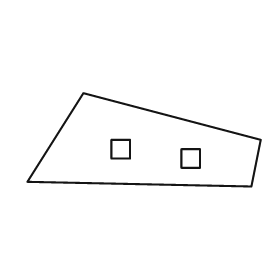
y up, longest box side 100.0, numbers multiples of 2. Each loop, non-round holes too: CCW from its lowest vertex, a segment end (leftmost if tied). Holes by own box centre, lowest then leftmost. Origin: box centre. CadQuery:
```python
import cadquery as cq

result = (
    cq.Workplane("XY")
    .moveTo(46.0, -20.0)
    .lineTo(50.0, 0.0)
    .lineTo(-26.0, 20.0)
    .lineTo(-50.0, -18.0)
    .close()
    .moveTo(16.0, -12.0)
    .lineTo(24.0, -12.0)
    .lineTo(24.0, -4.0)
    .lineTo(16.0, -4.0)
    .close()
    .moveTo(-14.0, -8.0)
    .lineTo(-6.0, -8.0)
    .lineTo(-6.0, 0.0)
    .lineTo(-14.0, 0.0)
    .close()
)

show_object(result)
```